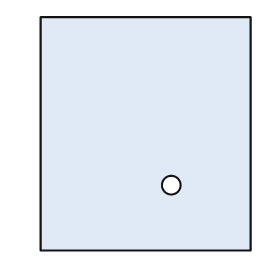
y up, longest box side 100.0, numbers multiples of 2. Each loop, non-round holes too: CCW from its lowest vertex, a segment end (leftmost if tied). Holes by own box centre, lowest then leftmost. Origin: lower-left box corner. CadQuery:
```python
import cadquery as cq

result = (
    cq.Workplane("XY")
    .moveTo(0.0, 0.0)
    .lineTo(90.0, 0.0)
    .lineTo(90.0, 100.0)
    .lineTo(0.0, 100.0)
    .close()
    .moveTo(56.0, 28.0)
    .circle(4.0)
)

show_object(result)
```